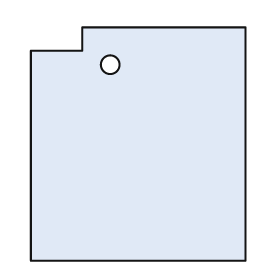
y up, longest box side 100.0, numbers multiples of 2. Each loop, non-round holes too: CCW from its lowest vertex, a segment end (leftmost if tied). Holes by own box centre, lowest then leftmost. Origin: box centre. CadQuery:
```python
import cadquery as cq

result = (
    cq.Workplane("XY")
    .moveTo(-46.0, -50.0)
    .lineTo(46.0, -50.0)
    .lineTo(46.0, 50.0)
    .lineTo(-24.0, 50.0)
    .lineTo(-24.0, 40.0)
    .lineTo(-46.0, 40.0)
    .close()
    .moveTo(-12.0, 34.0)
    .circle(4.0)
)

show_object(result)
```